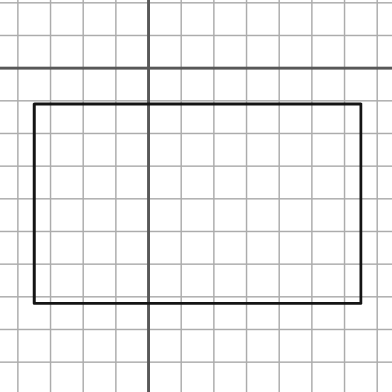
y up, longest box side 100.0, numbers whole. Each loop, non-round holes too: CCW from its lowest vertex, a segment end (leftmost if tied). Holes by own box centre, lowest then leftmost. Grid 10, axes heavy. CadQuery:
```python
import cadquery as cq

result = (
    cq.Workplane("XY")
    .moveTo(-35.0, -72.0)
    .lineTo(65.0, -72.0)
    .lineTo(65.0, -11.0)
    .lineTo(-35.0, -11.0)
    .close()
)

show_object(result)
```